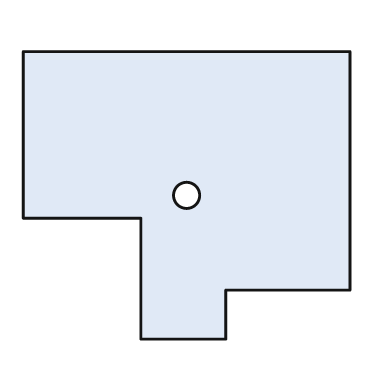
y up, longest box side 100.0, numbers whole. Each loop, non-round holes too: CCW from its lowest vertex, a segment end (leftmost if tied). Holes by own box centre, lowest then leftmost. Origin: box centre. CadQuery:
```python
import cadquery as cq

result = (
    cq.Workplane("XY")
    .moveTo(-14.0, -44.0)
    .lineTo(12.0, -44.0)
    .lineTo(12.0, -29.0)
    .lineTo(50.0, -29.0)
    .lineTo(50.0, 44.0)
    .lineTo(-50.0, 44.0)
    .lineTo(-50.0, -7.0)
    .lineTo(-14.0, -7.0)
    .close()
    .moveTo(0.0, 0.0)
    .circle(4.0)
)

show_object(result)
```